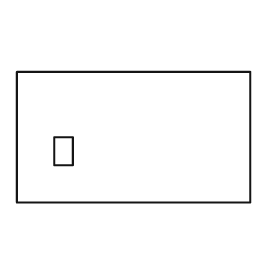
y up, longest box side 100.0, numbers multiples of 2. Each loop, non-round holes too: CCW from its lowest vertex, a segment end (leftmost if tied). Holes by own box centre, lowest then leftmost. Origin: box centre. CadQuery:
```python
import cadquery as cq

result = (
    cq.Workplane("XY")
    .moveTo(-50.0, -28.0)
    .lineTo(50.0, -28.0)
    .lineTo(50.0, 28.0)
    .lineTo(-50.0, 28.0)
    .close()
    .moveTo(-34.0, -12.0)
    .lineTo(-26.0, -12.0)
    .lineTo(-26.0, 0.0)
    .lineTo(-34.0, 0.0)
    .close()
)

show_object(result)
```